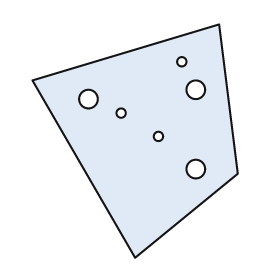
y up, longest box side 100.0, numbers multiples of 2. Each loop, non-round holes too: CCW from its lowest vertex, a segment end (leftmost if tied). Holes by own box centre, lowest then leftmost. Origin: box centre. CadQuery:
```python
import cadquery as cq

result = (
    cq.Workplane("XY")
    .moveTo(0.0, -50.0)
    .lineTo(44.0, -14.0)
    .lineTo(36.0, 50.0)
    .lineTo(-44.0, 26.0)
    .close()
    .moveTo(26.0, -12.0)
    .circle(4.0)
    .moveTo(10.0, 2.0)
    .circle(2.0)
    .moveTo(-6.0, 12.0)
    .circle(2.0)
    .moveTo(-20.0, 18.0)
    .circle(4.0)
    .moveTo(26.0, 22.0)
    .circle(4.0)
    .moveTo(20.0, 34.0)
    .circle(2.0)
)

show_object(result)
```